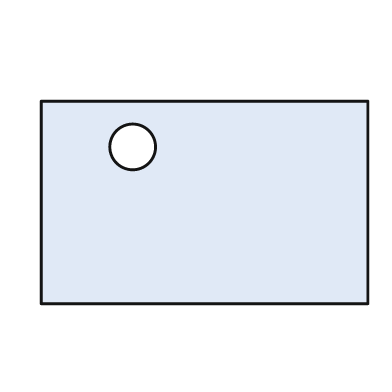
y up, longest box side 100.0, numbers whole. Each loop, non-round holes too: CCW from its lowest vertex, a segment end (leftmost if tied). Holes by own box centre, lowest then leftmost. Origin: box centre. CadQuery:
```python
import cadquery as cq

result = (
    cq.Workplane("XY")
    .moveTo(-50.0, -31.0)
    .lineTo(50.0, -31.0)
    .lineTo(50.0, 31.0)
    .lineTo(-50.0, 31.0)
    .close()
    .moveTo(-22.0, 17.0)
    .circle(7.0)
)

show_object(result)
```